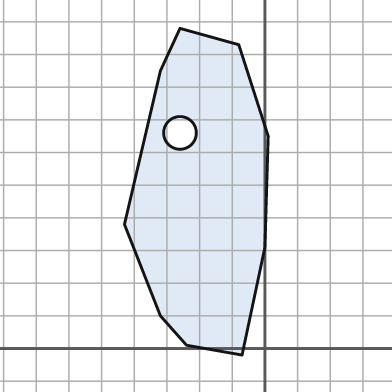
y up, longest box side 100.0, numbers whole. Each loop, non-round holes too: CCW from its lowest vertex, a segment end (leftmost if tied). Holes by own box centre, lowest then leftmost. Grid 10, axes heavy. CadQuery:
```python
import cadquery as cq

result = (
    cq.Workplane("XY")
    .moveTo(-7.0, -2.0)
    .lineTo(0.0, 31.0)
    .lineTo(1.0, 65.0)
    .lineTo(-8.0, 93.0)
    .lineTo(-26.0, 98.0)
    .lineTo(-32.0, 85.0)
    .lineTo(-43.0, 38.0)
    .lineTo(-32.0, 10.0)
    .lineTo(-24.0, 1.0)
    .close()
    .moveTo(-26.0, 66.0)
    .circle(5.0)
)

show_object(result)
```